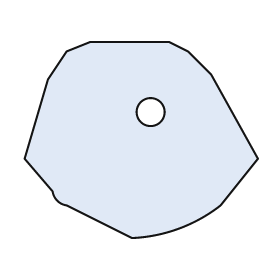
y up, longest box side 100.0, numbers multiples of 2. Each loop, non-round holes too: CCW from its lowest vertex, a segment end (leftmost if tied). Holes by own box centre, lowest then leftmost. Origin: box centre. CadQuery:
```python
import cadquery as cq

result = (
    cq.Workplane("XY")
    .moveTo(-4.0, -42.0)
    .threePointArc((16.0, -38.0), (34.0, -28.0))
    .lineTo(50.0, -8.0)
    .lineTo(30.0, 28.0)
    .lineTo(20.0, 38.0)
    .lineTo(12.0, 42.0)
    .lineTo(-22.0, 42.0)
    .lineTo(-32.0, 38.0)
    .lineTo(-40.0, 26.0)
    .lineTo(-50.0, -8.0)
    .lineTo(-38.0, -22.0)
    .threePointArc((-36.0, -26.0), (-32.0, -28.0))
    .close()
    .moveTo(4.0, 12.0)
    .circle(6.0)
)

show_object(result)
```